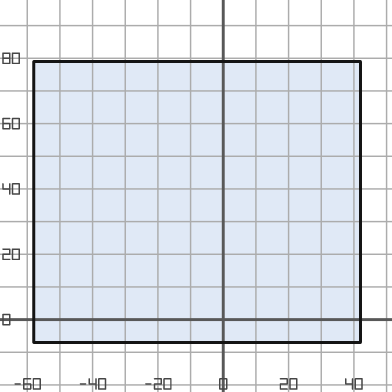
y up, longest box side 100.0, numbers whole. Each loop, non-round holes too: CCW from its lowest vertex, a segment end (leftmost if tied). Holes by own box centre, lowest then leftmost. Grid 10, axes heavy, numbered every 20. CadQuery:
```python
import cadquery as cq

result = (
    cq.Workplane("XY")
    .moveTo(-58.0, -7.0)
    .lineTo(42.0, -7.0)
    .lineTo(42.0, 79.0)
    .lineTo(-58.0, 79.0)
    .close()
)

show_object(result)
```